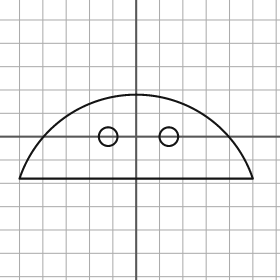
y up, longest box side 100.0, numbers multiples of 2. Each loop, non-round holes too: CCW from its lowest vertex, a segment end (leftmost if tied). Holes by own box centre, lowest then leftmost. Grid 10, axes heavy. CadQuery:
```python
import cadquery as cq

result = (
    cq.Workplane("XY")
    .moveTo(-50.0, -18.0)
    .lineTo(50.0, -18.0)
    .threePointArc((0.0, 18.0), (-50.0, -18.0))
    .close()
    .moveTo(-12.0, 0.0)
    .circle(4.0)
    .moveTo(14.0, 0.0)
    .circle(4.0)
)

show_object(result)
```